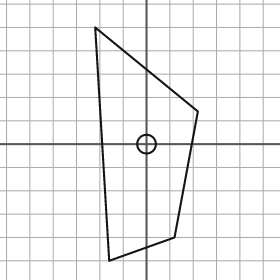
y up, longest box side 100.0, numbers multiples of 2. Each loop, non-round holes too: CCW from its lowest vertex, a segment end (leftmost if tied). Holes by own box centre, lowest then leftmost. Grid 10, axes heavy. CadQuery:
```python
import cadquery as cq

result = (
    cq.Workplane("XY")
    .moveTo(-16.0, -50.0)
    .lineTo(12.0, -40.0)
    .lineTo(22.0, 14.0)
    .lineTo(-22.0, 50.0)
    .close()
    .moveTo(0.0, 0.0)
    .circle(4.0)
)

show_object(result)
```